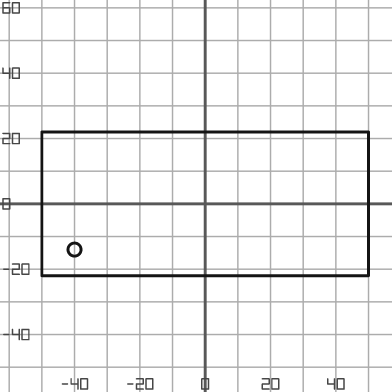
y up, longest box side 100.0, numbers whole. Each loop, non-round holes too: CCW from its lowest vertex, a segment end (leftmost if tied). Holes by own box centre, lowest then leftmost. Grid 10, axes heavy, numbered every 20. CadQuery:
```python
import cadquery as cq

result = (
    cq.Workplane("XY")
    .moveTo(-50.0, -22.0)
    .lineTo(50.0, -22.0)
    .lineTo(50.0, 22.0)
    .lineTo(-50.0, 22.0)
    .close()
    .moveTo(-40.0, -14.0)
    .circle(2.0)
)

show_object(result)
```